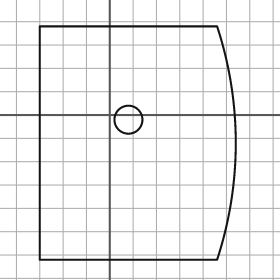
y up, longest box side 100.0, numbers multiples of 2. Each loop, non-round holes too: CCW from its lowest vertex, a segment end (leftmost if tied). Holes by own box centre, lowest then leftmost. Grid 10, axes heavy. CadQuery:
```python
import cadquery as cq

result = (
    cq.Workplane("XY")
    .moveTo(-30.0, -62.0)
    .lineTo(46.0, -62.0)
    .threePointArc((54.0, -12.0), (46.0, 38.0))
    .lineTo(-30.0, 38.0)
    .close()
    .moveTo(8.0, -2.0)
    .circle(6.0)
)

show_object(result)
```